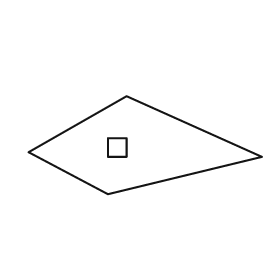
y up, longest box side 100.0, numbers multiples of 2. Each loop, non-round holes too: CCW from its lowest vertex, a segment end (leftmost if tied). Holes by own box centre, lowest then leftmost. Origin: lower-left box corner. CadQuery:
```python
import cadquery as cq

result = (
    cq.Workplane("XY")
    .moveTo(34.0, 0.0)
    .lineTo(100.0, 16.0)
    .lineTo(42.0, 42.0)
    .lineTo(0.0, 18.0)
    .close()
    .moveTo(34.0, 16.0)
    .lineTo(42.0, 16.0)
    .lineTo(42.0, 24.0)
    .lineTo(34.0, 24.0)
    .close()
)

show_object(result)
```